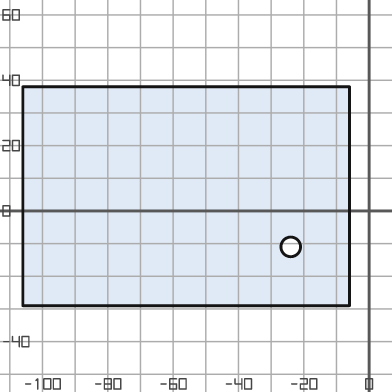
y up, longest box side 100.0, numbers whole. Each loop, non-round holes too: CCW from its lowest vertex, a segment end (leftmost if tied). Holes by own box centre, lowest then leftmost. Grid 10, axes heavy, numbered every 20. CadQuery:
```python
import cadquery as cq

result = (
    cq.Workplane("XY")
    .moveTo(-106.0, -29.0)
    .lineTo(-6.0, -29.0)
    .lineTo(-6.0, 38.0)
    .lineTo(-106.0, 38.0)
    .close()
    .moveTo(-24.0, -11.0)
    .circle(3.0)
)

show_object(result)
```